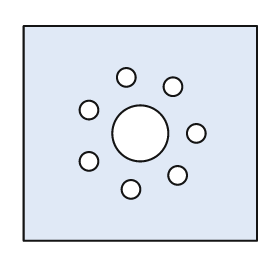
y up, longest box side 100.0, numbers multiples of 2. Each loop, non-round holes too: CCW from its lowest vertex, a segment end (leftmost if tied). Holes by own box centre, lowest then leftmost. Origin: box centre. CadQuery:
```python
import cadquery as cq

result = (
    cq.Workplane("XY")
    .moveTo(-50.0, -46.0)
    .lineTo(50.0, -46.0)
    .lineTo(50.0, 46.0)
    .lineTo(-50.0, 46.0)
    .close()
    .moveTo(-4.0, -24.0)
    .circle(4.0)
    .moveTo(16.0, -18.0)
    .circle(4.0)
    .moveTo(-22.0, -12.0)
    .circle(4.0)
    .moveTo(0.0, 0.0)
    .circle(12.0)
    .moveTo(24.0, 0.0)
    .circle(4.0)
    .moveTo(-22.0, 10.0)
    .circle(4.0)
    .moveTo(14.0, 20.0)
    .circle(4.0)
    .moveTo(-6.0, 24.0)
    .circle(4.0)
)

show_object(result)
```